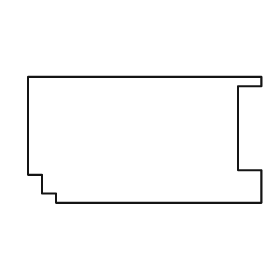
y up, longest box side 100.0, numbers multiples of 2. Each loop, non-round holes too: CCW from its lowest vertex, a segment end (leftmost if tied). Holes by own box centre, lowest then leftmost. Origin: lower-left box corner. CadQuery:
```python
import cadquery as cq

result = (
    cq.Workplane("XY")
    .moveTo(12.0, 0.0)
    .lineTo(100.0, 0.0)
    .lineTo(100.0, 14.0)
    .lineTo(90.0, 14.0)
    .lineTo(90.0, 50.0)
    .lineTo(100.0, 50.0)
    .lineTo(100.0, 54.0)
    .lineTo(0.0, 54.0)
    .lineTo(0.0, 12.0)
    .lineTo(6.0, 12.0)
    .lineTo(6.0, 4.0)
    .lineTo(12.0, 4.0)
    .close()
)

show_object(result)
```